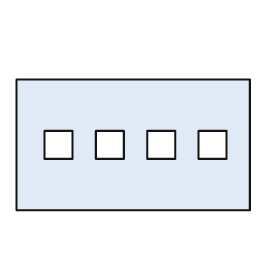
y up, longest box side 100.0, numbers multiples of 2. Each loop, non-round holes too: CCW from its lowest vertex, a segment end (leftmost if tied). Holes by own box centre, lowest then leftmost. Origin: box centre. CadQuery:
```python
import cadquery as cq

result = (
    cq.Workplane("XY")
    .moveTo(-50.0, -28.0)
    .lineTo(50.0, -28.0)
    .lineTo(50.0, 28.0)
    .lineTo(-50.0, 28.0)
    .close()
    .moveTo(-38.0, -6.0)
    .lineTo(-26.0, -6.0)
    .lineTo(-26.0, 6.0)
    .lineTo(-38.0, 6.0)
    .close()
    .moveTo(-16.0, -6.0)
    .lineTo(-4.0, -6.0)
    .lineTo(-4.0, 6.0)
    .lineTo(-16.0, 6.0)
    .close()
    .moveTo(6.0, -6.0)
    .lineTo(18.0, -6.0)
    .lineTo(18.0, 6.0)
    .lineTo(6.0, 6.0)
    .close()
    .moveTo(28.0, -6.0)
    .lineTo(40.0, -6.0)
    .lineTo(40.0, 6.0)
    .lineTo(28.0, 6.0)
    .close()
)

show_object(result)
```